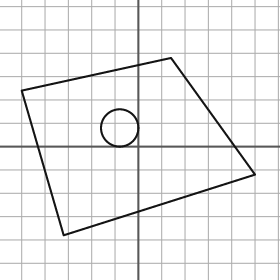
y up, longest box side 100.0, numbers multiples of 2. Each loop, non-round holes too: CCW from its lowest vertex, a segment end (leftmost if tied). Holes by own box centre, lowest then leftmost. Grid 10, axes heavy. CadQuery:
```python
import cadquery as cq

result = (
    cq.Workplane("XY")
    .moveTo(-32.0, -38.0)
    .lineTo(50.0, -12.0)
    .lineTo(14.0, 38.0)
    .lineTo(-50.0, 24.0)
    .close()
    .moveTo(-8.0, 8.0)
    .circle(8.0)
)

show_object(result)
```